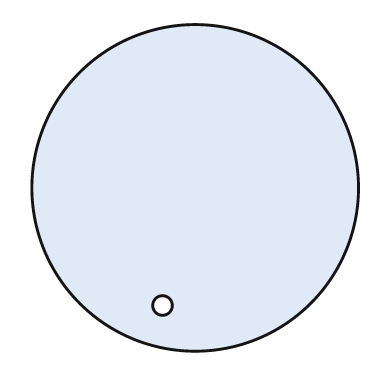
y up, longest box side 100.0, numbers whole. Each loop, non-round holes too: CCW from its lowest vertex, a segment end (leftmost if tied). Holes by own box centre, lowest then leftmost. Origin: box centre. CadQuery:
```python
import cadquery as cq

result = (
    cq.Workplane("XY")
    .moveTo(0.0, 0.0)
    .circle(50.0)
    .moveTo(-10.0, -36.0)
    .circle(3.0)
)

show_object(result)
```